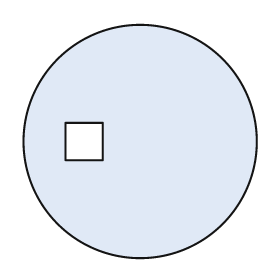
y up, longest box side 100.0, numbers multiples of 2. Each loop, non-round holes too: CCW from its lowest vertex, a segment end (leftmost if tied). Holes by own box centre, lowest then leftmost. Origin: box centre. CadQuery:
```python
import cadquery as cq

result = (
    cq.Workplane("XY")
    .moveTo(0.0, 0.0)
    .circle(50.0)
    .moveTo(-32.0, -8.0)
    .lineTo(-16.0, -8.0)
    .lineTo(-16.0, 8.0)
    .lineTo(-32.0, 8.0)
    .close()
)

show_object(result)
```